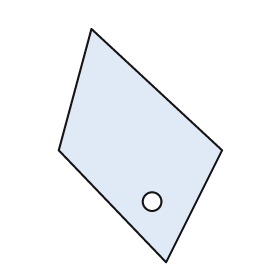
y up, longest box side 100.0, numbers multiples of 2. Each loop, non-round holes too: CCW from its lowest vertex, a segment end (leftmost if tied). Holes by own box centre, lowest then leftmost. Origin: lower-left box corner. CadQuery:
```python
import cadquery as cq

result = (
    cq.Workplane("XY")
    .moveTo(46.0, 0.0)
    .lineTo(70.0, 48.0)
    .lineTo(14.0, 100.0)
    .lineTo(0.0, 48.0)
    .close()
    .moveTo(40.0, 26.0)
    .circle(4.0)
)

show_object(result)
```